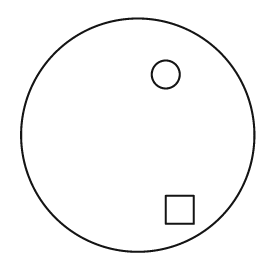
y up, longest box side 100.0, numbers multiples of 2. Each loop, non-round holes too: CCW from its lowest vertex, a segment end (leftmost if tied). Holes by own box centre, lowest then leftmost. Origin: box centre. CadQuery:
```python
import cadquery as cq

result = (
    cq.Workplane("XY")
    .moveTo(0.0, 0.0)
    .circle(50.0)
    .moveTo(12.0, -38.0)
    .lineTo(24.0, -38.0)
    .lineTo(24.0, -26.0)
    .lineTo(12.0, -26.0)
    .close()
    .moveTo(12.0, 26.0)
    .circle(6.0)
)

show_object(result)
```